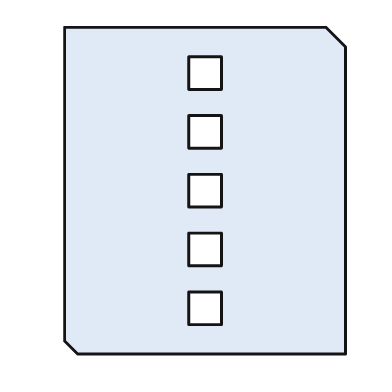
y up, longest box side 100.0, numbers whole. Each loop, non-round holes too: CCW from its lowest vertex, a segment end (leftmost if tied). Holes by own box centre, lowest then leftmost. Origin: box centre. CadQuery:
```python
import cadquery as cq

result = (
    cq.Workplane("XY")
    .moveTo(-39.0, -50.0)
    .lineTo(43.0, -50.0)
    .lineTo(43.0, 44.0)
    .lineTo(37.0, 50.0)
    .lineTo(-43.0, 50.0)
    .lineTo(-43.0, -46.0)
    .close()
    .moveTo(-5.0, -41.0)
    .lineTo(5.0, -41.0)
    .lineTo(5.0, -31.0)
    .lineTo(-5.0, -31.0)
    .close()
    .moveTo(-5.0, -23.0)
    .lineTo(5.0, -23.0)
    .lineTo(5.0, -13.0)
    .lineTo(-5.0, -13.0)
    .close()
    .moveTo(-5.0, -5.0)
    .lineTo(5.0, -5.0)
    .lineTo(5.0, 5.0)
    .lineTo(-5.0, 5.0)
    .close()
    .moveTo(-5.0, 13.0)
    .lineTo(5.0, 13.0)
    .lineTo(5.0, 23.0)
    .lineTo(-5.0, 23.0)
    .close()
    .moveTo(-5.0, 31.0)
    .lineTo(5.0, 31.0)
    .lineTo(5.0, 41.0)
    .lineTo(-5.0, 41.0)
    .close()
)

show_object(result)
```